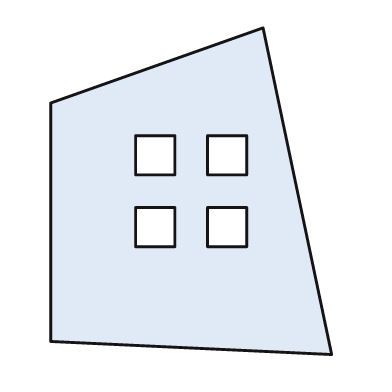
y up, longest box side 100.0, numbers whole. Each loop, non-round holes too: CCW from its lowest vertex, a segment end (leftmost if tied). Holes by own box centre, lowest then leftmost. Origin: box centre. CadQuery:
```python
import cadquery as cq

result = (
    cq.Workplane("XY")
    .moveTo(43.0, -50.0)
    .lineTo(22.0, 50.0)
    .lineTo(-43.0, 27.0)
    .lineTo(-43.0, -46.0)
    .close()
    .moveTo(-17.0, -17.0)
    .lineTo(-5.0, -17.0)
    .lineTo(-5.0, -5.0)
    .lineTo(-17.0, -5.0)
    .close()
    .moveTo(5.0, -17.0)
    .lineTo(17.0, -17.0)
    .lineTo(17.0, -5.0)
    .lineTo(5.0, -5.0)
    .close()
    .moveTo(-17.0, 5.0)
    .lineTo(-5.0, 5.0)
    .lineTo(-5.0, 17.0)
    .lineTo(-17.0, 17.0)
    .close()
    .moveTo(5.0, 5.0)
    .lineTo(17.0, 5.0)
    .lineTo(17.0, 17.0)
    .lineTo(5.0, 17.0)
    .close()
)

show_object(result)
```